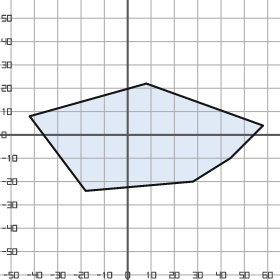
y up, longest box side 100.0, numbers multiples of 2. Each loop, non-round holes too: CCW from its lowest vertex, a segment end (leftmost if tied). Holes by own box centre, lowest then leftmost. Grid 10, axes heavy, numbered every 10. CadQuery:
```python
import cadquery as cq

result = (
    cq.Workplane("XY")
    .moveTo(-18.0, -24.0)
    .lineTo(28.0, -20.0)
    .lineTo(44.0, -10.0)
    .lineTo(58.0, 4.0)
    .lineTo(8.0, 22.0)
    .lineTo(-42.0, 8.0)
    .close()
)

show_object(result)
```